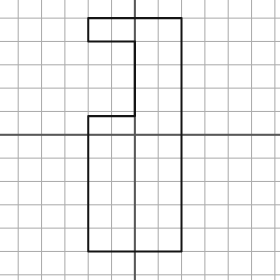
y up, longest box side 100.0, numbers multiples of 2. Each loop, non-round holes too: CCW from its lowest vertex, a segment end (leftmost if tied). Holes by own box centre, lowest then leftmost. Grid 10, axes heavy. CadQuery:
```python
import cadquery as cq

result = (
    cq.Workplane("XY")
    .moveTo(-20.0, -50.0)
    .lineTo(20.0, -50.0)
    .lineTo(20.0, 50.0)
    .lineTo(-20.0, 50.0)
    .lineTo(-20.0, 40.0)
    .lineTo(0.0, 40.0)
    .lineTo(0.0, 8.0)
    .lineTo(-20.0, 8.0)
    .close()
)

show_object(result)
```